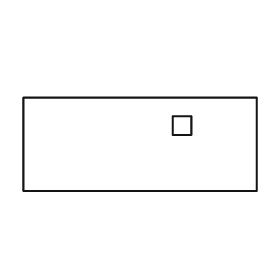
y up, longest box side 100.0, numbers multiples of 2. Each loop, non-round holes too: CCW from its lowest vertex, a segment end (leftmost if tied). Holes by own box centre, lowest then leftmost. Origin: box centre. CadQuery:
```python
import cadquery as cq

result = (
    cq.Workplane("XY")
    .moveTo(-50.0, -20.0)
    .lineTo(50.0, -20.0)
    .lineTo(50.0, 20.0)
    .lineTo(-50.0, 20.0)
    .close()
    .moveTo(14.0, 4.0)
    .lineTo(22.0, 4.0)
    .lineTo(22.0, 12.0)
    .lineTo(14.0, 12.0)
    .close()
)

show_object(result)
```